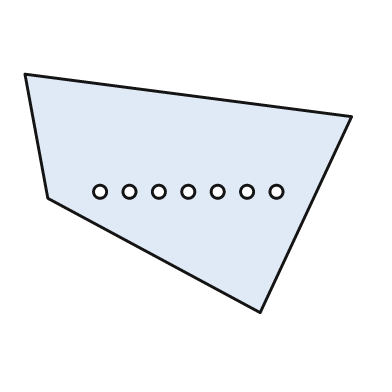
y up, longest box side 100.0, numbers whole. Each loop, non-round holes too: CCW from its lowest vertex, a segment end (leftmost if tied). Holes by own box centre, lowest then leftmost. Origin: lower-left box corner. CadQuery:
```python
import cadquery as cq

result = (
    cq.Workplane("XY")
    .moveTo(72.0, 0.0)
    .lineTo(100.0, 60.0)
    .lineTo(0.0, 73.0)
    .lineTo(7.0, 35.0)
    .close()
    .moveTo(23.0, 37.0)
    .circle(2.0)
    .moveTo(32.0, 37.0)
    .circle(2.0)
    .moveTo(41.0, 37.0)
    .circle(2.0)
    .moveTo(50.0, 37.0)
    .circle(2.0)
    .moveTo(59.0, 37.0)
    .circle(2.0)
    .moveTo(68.0, 37.0)
    .circle(2.0)
    .moveTo(77.0, 37.0)
    .circle(2.0)
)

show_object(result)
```